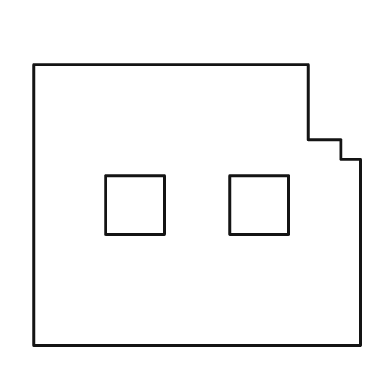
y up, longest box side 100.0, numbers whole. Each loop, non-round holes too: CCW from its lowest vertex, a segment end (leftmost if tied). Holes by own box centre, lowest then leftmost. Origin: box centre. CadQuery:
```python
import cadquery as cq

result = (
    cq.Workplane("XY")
    .moveTo(-50.0, -43.0)
    .lineTo(50.0, -43.0)
    .lineTo(50.0, 14.0)
    .lineTo(44.0, 14.0)
    .lineTo(44.0, 20.0)
    .lineTo(34.0, 20.0)
    .lineTo(34.0, 43.0)
    .lineTo(-50.0, 43.0)
    .close()
    .moveTo(-28.0, -9.0)
    .lineTo(-10.0, -9.0)
    .lineTo(-10.0, 9.0)
    .lineTo(-28.0, 9.0)
    .close()
    .moveTo(10.0, -9.0)
    .lineTo(28.0, -9.0)
    .lineTo(28.0, 9.0)
    .lineTo(10.0, 9.0)
    .close()
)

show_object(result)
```